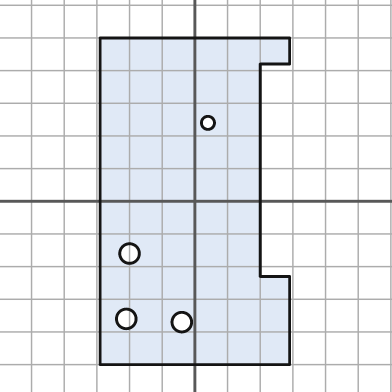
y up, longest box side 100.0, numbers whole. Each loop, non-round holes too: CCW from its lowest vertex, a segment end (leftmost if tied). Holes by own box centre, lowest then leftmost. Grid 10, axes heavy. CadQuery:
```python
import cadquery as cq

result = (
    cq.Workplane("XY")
    .moveTo(-29.0, -50.0)
    .lineTo(29.0, -50.0)
    .lineTo(29.0, -23.0)
    .lineTo(20.0, -23.0)
    .lineTo(20.0, 42.0)
    .lineTo(29.0, 42.0)
    .lineTo(29.0, 50.0)
    .lineTo(-29.0, 50.0)
    .close()
    .moveTo(-4.0, -37.0)
    .circle(3.0)
    .moveTo(-21.0, -36.0)
    .circle(3.0)
    .moveTo(-20.0, -16.0)
    .circle(3.0)
    .moveTo(4.0, 24.0)
    .circle(2.0)
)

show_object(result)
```